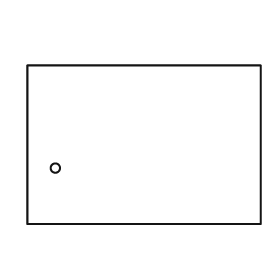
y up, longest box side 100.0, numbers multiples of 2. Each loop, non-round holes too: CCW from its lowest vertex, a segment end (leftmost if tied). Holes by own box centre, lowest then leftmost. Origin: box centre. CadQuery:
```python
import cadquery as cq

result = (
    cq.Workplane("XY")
    .moveTo(-50.0, -34.0)
    .lineTo(50.0, -34.0)
    .lineTo(50.0, 34.0)
    .lineTo(-50.0, 34.0)
    .close()
    .moveTo(-38.0, -10.0)
    .circle(2.0)
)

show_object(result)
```